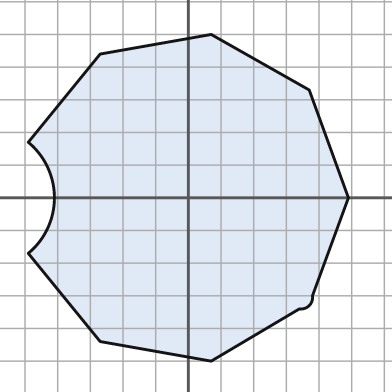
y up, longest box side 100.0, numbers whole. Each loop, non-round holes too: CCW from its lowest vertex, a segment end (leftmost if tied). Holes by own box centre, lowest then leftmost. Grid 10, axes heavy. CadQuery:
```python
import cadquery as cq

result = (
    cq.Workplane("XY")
    .moveTo(7.0, -50.0)
    .lineTo(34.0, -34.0)
    .threePointArc((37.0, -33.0), (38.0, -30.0))
    .lineTo(49.0, 0.0)
    .lineTo(37.0, 33.0)
    .lineTo(7.0, 50.0)
    .lineTo(-27.0, 44.0)
    .lineTo(-49.0, 17.0)
    .threePointArc((-41.0, 0.0), (-49.0, -17.0))
    .lineTo(-27.0, -44.0)
    .close()
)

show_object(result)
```